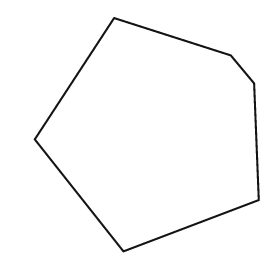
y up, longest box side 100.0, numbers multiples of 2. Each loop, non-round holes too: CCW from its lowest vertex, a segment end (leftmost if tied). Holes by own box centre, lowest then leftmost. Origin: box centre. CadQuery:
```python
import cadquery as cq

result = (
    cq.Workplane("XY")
    .moveTo(-10.0, -50.0)
    .lineTo(48.0, -28.0)
    .lineTo(46.0, 22.0)
    .lineTo(36.0, 34.0)
    .lineTo(-14.0, 50.0)
    .lineTo(-48.0, -2.0)
    .close()
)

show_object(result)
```